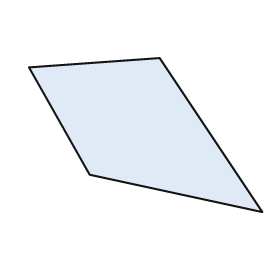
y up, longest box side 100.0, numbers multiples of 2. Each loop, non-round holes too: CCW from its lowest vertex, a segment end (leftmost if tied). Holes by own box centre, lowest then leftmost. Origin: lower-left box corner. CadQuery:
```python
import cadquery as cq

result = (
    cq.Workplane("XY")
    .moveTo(100.0, 0.0)
    .lineTo(56.0, 66.0)
    .lineTo(0.0, 62.0)
    .lineTo(26.0, 16.0)
    .close()
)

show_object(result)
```